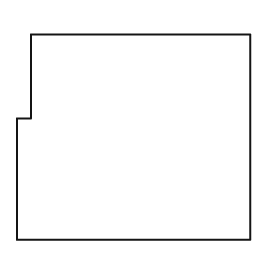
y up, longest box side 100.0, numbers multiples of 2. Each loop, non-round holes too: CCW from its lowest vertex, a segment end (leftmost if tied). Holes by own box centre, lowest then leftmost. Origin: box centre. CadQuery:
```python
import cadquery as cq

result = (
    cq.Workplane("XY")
    .moveTo(-50.0, -44.0)
    .lineTo(50.0, -44.0)
    .lineTo(50.0, 44.0)
    .lineTo(-44.0, 44.0)
    .lineTo(-44.0, 8.0)
    .lineTo(-50.0, 8.0)
    .close()
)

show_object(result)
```